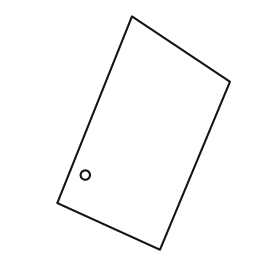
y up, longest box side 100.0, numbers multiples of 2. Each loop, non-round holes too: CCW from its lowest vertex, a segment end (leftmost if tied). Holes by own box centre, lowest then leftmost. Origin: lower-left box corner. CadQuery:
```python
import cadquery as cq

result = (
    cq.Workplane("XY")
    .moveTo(44.0, 0.0)
    .lineTo(74.0, 72.0)
    .lineTo(32.0, 100.0)
    .lineTo(0.0, 20.0)
    .close()
    .moveTo(12.0, 32.0)
    .circle(2.0)
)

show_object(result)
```